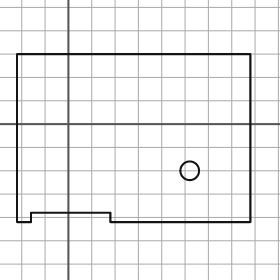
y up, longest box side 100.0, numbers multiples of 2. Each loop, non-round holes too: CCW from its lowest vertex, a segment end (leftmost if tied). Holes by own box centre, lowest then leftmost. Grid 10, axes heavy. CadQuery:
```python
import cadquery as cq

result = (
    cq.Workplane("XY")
    .moveTo(-22.0, -42.0)
    .lineTo(-16.0, -42.0)
    .lineTo(-16.0, -38.0)
    .lineTo(18.0, -38.0)
    .lineTo(18.0, -42.0)
    .lineTo(78.0, -42.0)
    .lineTo(78.0, 30.0)
    .lineTo(-22.0, 30.0)
    .close()
    .moveTo(52.0, -20.0)
    .circle(4.0)
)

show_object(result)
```